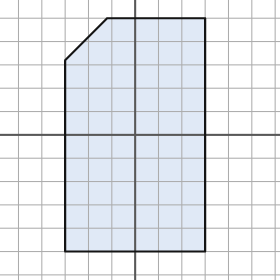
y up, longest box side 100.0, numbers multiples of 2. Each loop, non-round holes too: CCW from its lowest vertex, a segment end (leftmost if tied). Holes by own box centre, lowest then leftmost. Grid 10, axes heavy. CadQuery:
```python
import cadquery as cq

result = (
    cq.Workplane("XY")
    .moveTo(-30.0, -50.0)
    .lineTo(30.0, -50.0)
    .lineTo(30.0, 50.0)
    .lineTo(-12.0, 50.0)
    .lineTo(-30.0, 32.0)
    .close()
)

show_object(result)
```